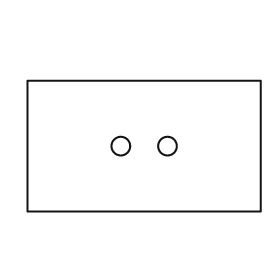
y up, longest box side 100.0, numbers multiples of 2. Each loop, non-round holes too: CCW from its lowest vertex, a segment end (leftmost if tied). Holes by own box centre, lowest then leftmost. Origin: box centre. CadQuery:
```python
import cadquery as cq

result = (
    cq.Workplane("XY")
    .moveTo(-50.0, -28.0)
    .lineTo(50.0, -28.0)
    .lineTo(50.0, 28.0)
    .lineTo(-50.0, 28.0)
    .close()
    .moveTo(-10.0, 0.0)
    .circle(4.0)
    .moveTo(10.0, 0.0)
    .circle(4.0)
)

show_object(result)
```